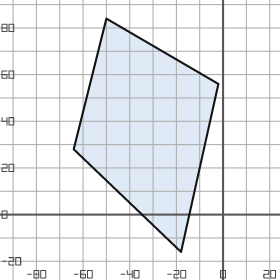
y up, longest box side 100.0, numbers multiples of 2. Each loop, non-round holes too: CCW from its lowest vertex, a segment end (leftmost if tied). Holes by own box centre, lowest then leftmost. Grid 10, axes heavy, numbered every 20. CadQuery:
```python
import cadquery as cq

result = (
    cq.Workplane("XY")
    .moveTo(-18.0, -16.0)
    .lineTo(-2.0, 56.0)
    .lineTo(-50.0, 84.0)
    .lineTo(-64.0, 28.0)
    .close()
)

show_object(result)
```